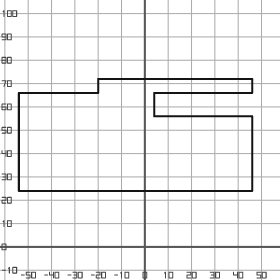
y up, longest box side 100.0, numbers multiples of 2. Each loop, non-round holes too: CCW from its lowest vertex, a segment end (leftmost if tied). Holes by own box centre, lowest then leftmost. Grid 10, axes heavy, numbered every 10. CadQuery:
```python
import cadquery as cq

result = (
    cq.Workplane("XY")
    .moveTo(-54.0, 24.0)
    .lineTo(46.0, 24.0)
    .lineTo(46.0, 56.0)
    .lineTo(4.0, 56.0)
    .lineTo(4.0, 66.0)
    .lineTo(46.0, 66.0)
    .lineTo(46.0, 72.0)
    .lineTo(-20.0, 72.0)
    .lineTo(-20.0, 66.0)
    .lineTo(-54.0, 66.0)
    .close()
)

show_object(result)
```